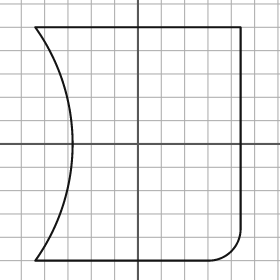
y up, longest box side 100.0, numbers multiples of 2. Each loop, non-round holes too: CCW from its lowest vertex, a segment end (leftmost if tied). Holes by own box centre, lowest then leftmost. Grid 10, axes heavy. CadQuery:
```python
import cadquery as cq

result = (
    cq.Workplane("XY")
    .moveTo(-44.0, -50.0)
    .lineTo(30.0, -50.0)
    .threePointArc((40.0, -46.0), (44.0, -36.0))
    .lineTo(44.0, 50.0)
    .lineTo(-44.0, 50.0)
    .threePointArc((-28.0, 0.0), (-44.0, -50.0))
    .close()
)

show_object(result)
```